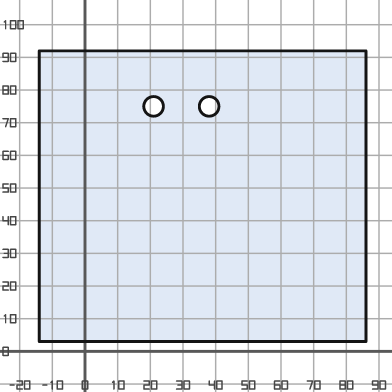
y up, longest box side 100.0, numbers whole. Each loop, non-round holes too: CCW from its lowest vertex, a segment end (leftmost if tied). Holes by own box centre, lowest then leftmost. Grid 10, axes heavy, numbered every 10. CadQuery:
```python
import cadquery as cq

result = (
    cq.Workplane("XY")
    .moveTo(-14.0, 3.0)
    .lineTo(86.0, 3.0)
    .lineTo(86.0, 92.0)
    .lineTo(-14.0, 92.0)
    .close()
    .moveTo(21.0, 75.0)
    .circle(3.0)
    .moveTo(38.0, 75.0)
    .circle(3.0)
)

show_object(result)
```